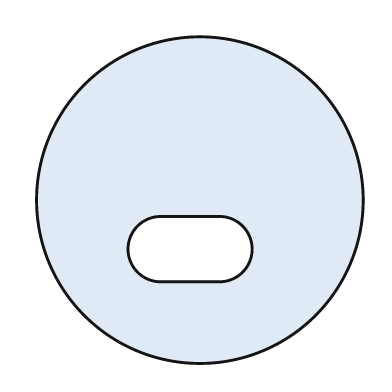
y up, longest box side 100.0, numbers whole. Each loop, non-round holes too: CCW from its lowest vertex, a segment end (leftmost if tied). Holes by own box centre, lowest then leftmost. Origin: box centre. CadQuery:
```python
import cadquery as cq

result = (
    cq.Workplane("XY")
    .moveTo(0.0, 0.0)
    .circle(50.0)
    .moveTo(-12.0, -25.0)
    .lineTo(6.0, -25.0)
    .threePointArc((16.0, -15.0), (6.0, -5.0))
    .lineTo(-12.0, -5.0)
    .threePointArc((-22.0, -15.0), (-12.0, -25.0))
    .close()
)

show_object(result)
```